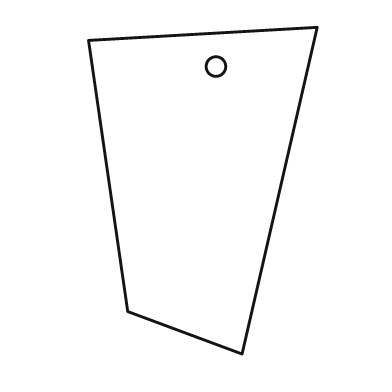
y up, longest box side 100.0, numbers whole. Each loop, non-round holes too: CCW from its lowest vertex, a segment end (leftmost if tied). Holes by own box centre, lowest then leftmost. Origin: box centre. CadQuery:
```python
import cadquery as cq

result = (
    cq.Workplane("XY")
    .moveTo(12.0, -50.0)
    .lineTo(35.0, 50.0)
    .lineTo(-35.0, 46.0)
    .lineTo(-23.0, -37.0)
    .close()
    .moveTo(4.0, 38.0)
    .circle(3.0)
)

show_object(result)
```